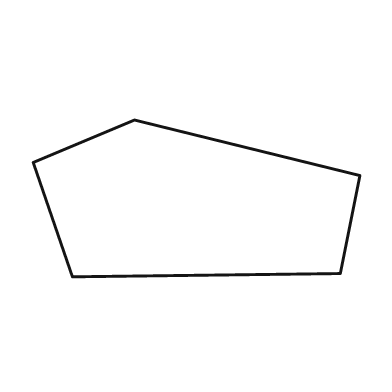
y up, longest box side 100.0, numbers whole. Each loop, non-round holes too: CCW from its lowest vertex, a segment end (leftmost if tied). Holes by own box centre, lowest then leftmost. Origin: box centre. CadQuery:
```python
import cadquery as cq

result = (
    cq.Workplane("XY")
    .moveTo(-38.0, -24.0)
    .lineTo(44.0, -23.0)
    .lineTo(50.0, 7.0)
    .lineTo(-19.0, 24.0)
    .lineTo(-50.0, 11.0)
    .close()
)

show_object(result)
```